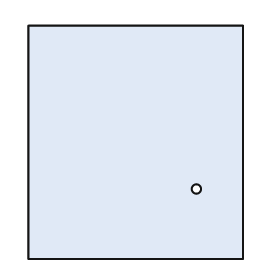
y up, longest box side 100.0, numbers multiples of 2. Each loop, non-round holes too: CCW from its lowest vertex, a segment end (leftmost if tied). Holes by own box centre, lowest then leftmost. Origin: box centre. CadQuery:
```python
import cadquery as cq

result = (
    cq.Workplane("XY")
    .moveTo(-46.0, -50.0)
    .lineTo(46.0, -50.0)
    .lineTo(46.0, 50.0)
    .lineTo(-46.0, 50.0)
    .close()
    .moveTo(26.0, -20.0)
    .circle(2.0)
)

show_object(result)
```